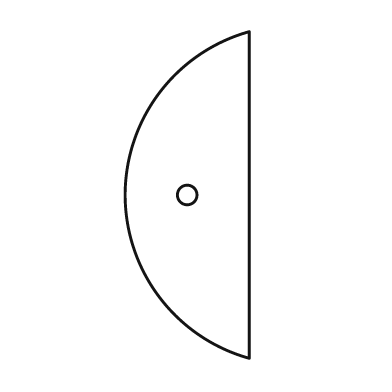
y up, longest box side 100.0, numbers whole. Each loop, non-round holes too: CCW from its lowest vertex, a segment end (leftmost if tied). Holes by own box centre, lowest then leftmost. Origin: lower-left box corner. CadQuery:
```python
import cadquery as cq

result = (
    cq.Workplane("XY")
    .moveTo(38.0, 0.0)
    .lineTo(38.0, 100.0)
    .threePointArc((0.0, 50.0), (38.0, 0.0))
    .close()
    .moveTo(19.0, 50.0)
    .circle(3.0)
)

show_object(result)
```